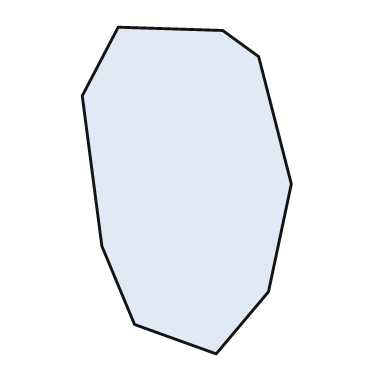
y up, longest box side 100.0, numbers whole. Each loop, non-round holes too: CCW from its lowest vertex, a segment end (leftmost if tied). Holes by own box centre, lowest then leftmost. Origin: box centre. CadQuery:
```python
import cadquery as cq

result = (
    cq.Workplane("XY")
    .moveTo(9.0, -50.0)
    .lineTo(25.0, -31.0)
    .lineTo(32.0, 2.0)
    .lineTo(22.0, 41.0)
    .lineTo(11.0, 49.0)
    .lineTo(-21.0, 50.0)
    .lineTo(-32.0, 29.0)
    .lineTo(-26.0, -17.0)
    .lineTo(-16.0, -41.0)
    .close()
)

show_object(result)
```